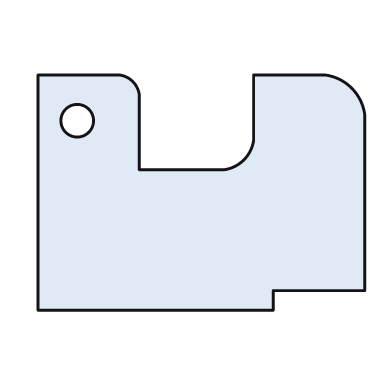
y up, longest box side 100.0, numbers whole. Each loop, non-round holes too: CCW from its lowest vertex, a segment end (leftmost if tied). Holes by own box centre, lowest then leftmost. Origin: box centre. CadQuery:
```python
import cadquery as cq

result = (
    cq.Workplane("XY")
    .moveTo(-50.0, -36.0)
    .lineTo(22.0, -36.0)
    .lineTo(22.0, -30.0)
    .lineTo(50.0, -30.0)
    .lineTo(50.0, 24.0)
    .threePointArc((46.0, 32.0), (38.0, 36.0))
    .lineTo(16.0, 36.0)
    .lineTo(16.0, 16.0)
    .threePointArc((13.0, 10.0), (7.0, 7.0))
    .lineTo(-19.0, 7.0)
    .lineTo(-19.0, 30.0)
    .threePointArc((-21.0, 34.0), (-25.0, 36.0))
    .lineTo(-50.0, 36.0)
    .close()
    .moveTo(-38.0, 22.0)
    .circle(5.0)
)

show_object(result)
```